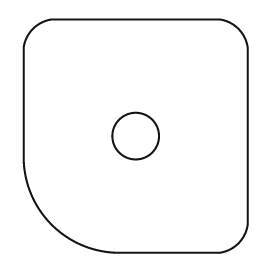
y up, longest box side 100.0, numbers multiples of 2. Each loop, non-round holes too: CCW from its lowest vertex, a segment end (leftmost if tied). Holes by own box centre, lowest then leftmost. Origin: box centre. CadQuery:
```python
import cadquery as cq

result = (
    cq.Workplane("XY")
    .moveTo(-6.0, -50.0)
    .lineTo(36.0, -50.0)
    .threePointArc((44.0, -46.0), (48.0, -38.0))
    .lineTo(48.0, 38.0)
    .threePointArc((44.0, 46.0), (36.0, 50.0))
    .lineTo(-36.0, 50.0)
    .threePointArc((-44.0, 46.0), (-48.0, 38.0))
    .lineTo(-48.0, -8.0)
    .threePointArc((-36.0, -38.0), (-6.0, -50.0))
    .close()
    .moveTo(0.0, 0.0)
    .circle(10.0)
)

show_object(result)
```